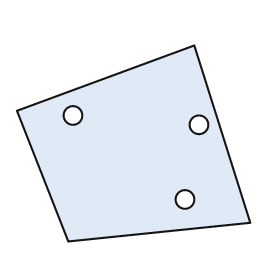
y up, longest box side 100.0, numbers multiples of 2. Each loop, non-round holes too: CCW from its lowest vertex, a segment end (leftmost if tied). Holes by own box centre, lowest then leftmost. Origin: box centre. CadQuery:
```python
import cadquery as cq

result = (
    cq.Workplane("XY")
    .moveTo(-28.0, -42.0)
    .lineTo(50.0, -34.0)
    .lineTo(26.0, 42.0)
    .lineTo(-50.0, 14.0)
    .close()
    .moveTo(22.0, -24.0)
    .circle(4.0)
    .moveTo(28.0, 8.0)
    .circle(4.0)
    .moveTo(-26.0, 12.0)
    .circle(4.0)
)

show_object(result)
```